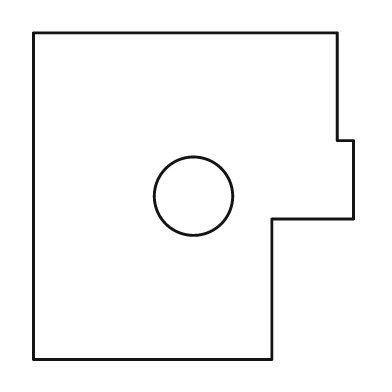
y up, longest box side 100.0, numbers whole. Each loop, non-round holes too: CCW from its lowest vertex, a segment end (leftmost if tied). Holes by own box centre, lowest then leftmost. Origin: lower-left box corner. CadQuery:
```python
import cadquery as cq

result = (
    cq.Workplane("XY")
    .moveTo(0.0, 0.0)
    .lineTo(73.0, 0.0)
    .lineTo(73.0, 43.0)
    .lineTo(98.0, 43.0)
    .lineTo(98.0, 67.0)
    .lineTo(93.0, 67.0)
    .lineTo(93.0, 100.0)
    .lineTo(0.0, 100.0)
    .close()
    .moveTo(49.0, 50.0)
    .circle(12.0)
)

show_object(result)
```